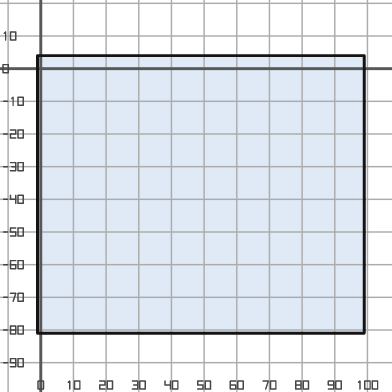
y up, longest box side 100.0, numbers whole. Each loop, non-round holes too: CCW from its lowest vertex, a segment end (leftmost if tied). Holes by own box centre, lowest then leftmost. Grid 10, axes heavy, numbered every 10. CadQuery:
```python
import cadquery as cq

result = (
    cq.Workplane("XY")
    .moveTo(-1.0, -81.0)
    .lineTo(99.0, -81.0)
    .lineTo(99.0, 4.0)
    .lineTo(-1.0, 4.0)
    .close()
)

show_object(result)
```